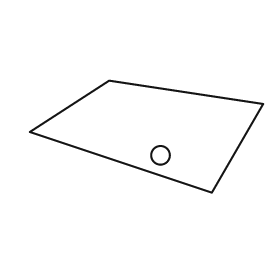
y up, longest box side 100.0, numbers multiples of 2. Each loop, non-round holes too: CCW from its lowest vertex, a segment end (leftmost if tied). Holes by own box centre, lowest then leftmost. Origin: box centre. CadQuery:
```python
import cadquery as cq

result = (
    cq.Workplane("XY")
    .moveTo(28.0, -24.0)
    .lineTo(50.0, 14.0)
    .lineTo(-16.0, 24.0)
    .lineTo(-50.0, 2.0)
    .close()
    .moveTo(6.0, -8.0)
    .circle(4.0)
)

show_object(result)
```